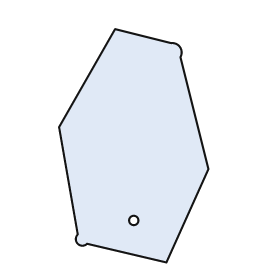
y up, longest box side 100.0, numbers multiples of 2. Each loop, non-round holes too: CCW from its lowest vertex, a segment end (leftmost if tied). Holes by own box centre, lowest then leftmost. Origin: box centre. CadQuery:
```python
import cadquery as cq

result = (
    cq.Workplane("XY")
    .moveTo(14.0, -50.0)
    .lineTo(32.0, -10.0)
    .lineTo(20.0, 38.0)
    .threePointArc((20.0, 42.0), (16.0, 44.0))
    .lineTo(-8.0, 50.0)
    .lineTo(-32.0, 8.0)
    .lineTo(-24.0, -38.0)
    .threePointArc((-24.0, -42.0), (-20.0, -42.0))
    .close()
    .moveTo(0.0, -32.0)
    .circle(2.0)
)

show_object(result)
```